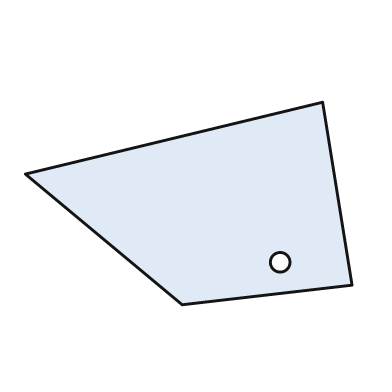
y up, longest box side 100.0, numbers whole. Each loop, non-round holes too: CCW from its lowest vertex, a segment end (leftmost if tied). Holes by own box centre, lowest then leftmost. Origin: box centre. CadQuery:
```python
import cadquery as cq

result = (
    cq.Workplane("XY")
    .moveTo(-2.0, -31.0)
    .lineTo(50.0, -25.0)
    .lineTo(41.0, 31.0)
    .lineTo(-50.0, 9.0)
    .close()
    .moveTo(28.0, -18.0)
    .circle(3.0)
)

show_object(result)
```